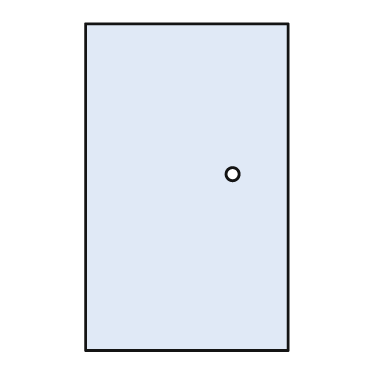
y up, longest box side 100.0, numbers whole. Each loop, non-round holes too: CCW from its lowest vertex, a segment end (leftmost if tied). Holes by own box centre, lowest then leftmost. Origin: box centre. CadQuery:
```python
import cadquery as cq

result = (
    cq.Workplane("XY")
    .moveTo(-31.0, -50.0)
    .lineTo(31.0, -50.0)
    .lineTo(31.0, 50.0)
    .lineTo(-31.0, 50.0)
    .close()
    .moveTo(14.0, 4.0)
    .circle(2.0)
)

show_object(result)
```